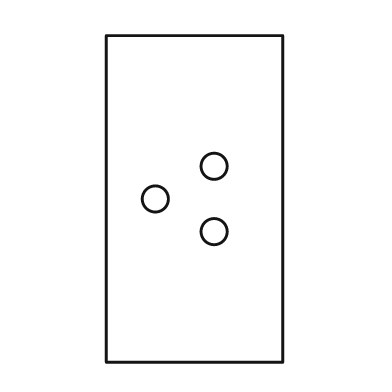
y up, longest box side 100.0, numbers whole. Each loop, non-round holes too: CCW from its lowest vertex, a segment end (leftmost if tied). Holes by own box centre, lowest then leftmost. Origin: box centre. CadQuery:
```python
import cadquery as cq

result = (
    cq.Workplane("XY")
    .moveTo(-27.0, -50.0)
    .lineTo(27.0, -50.0)
    .lineTo(27.0, 50.0)
    .lineTo(-27.0, 50.0)
    .close()
    .moveTo(6.0, -10.0)
    .circle(4.0)
    .moveTo(-12.0, 0.0)
    .circle(4.0)
    .moveTo(6.0, 10.0)
    .circle(4.0)
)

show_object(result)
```